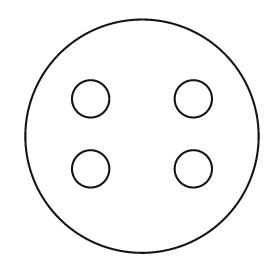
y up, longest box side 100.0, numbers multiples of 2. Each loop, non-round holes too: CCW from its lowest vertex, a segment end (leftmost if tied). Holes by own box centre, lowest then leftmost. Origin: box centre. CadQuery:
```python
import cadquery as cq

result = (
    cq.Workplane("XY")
    .moveTo(0.0, 0.0)
    .circle(50.0)
    .moveTo(-22.0, -14.0)
    .circle(8.0)
    .moveTo(22.0, -14.0)
    .circle(8.0)
    .moveTo(-22.0, 16.0)
    .circle(8.0)
    .moveTo(22.0, 16.0)
    .circle(8.0)
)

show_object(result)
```